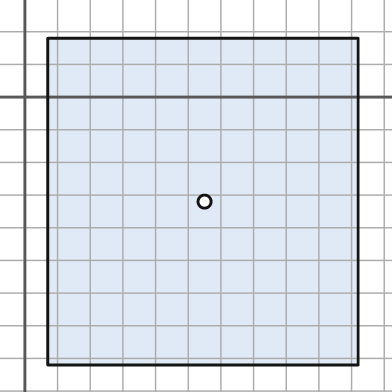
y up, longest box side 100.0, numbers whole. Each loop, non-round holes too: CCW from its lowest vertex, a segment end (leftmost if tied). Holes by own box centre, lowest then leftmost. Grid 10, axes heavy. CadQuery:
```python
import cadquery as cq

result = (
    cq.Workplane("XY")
    .moveTo(7.0, -82.0)
    .lineTo(102.0, -82.0)
    .lineTo(102.0, 18.0)
    .lineTo(7.0, 18.0)
    .close()
    .moveTo(55.0, -32.0)
    .circle(2.0)
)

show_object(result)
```